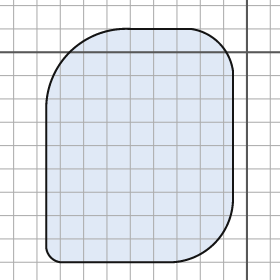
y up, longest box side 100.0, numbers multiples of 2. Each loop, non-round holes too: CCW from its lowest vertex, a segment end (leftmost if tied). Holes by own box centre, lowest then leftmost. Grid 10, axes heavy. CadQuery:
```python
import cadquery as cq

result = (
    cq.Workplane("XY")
    .moveTo(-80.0, -90.0)
    .lineTo(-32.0, -90.0)
    .threePointArc((-14.0, -82.0), (-6.0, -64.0))
    .lineTo(-6.0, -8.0)
    .threePointArc((-12.0, 4.0), (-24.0, 10.0))
    .lineTo(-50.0, 10.0)
    .threePointArc((-76.0, 0.0), (-86.0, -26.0))
    .lineTo(-86.0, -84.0)
    .threePointArc((-84.0, -88.0), (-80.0, -90.0))
    .close()
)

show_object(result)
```